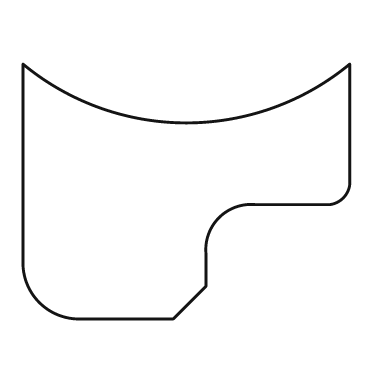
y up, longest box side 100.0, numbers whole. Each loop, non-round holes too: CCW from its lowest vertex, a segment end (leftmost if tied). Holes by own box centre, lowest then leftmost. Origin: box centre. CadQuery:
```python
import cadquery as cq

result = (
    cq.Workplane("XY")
    .moveTo(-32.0, -39.0)
    .lineTo(-4.0, -39.0)
    .lineTo(6.0, -29.0)
    .lineTo(6.0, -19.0)
    .threePointArc((10.0, -8.0), (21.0, -4.0))
    .lineTo(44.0, -4.0)
    .threePointArc((48.0, -2.0), (50.0, 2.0))
    .lineTo(50.0, 39.0)
    .threePointArc((0.0, 21.0), (-50.0, 39.0))
    .lineTo(-50.0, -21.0)
    .threePointArc((-45.0, -34.0), (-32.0, -39.0))
    .close()
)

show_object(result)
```